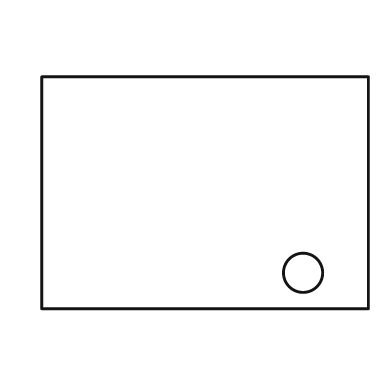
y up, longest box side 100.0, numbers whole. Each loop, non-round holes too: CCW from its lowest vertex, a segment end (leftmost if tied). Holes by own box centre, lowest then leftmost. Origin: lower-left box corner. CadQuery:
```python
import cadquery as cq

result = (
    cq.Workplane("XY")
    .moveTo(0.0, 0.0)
    .lineTo(100.0, 0.0)
    .lineTo(100.0, 71.0)
    .lineTo(0.0, 71.0)
    .close()
    .moveTo(80.0, 11.0)
    .circle(6.0)
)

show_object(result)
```